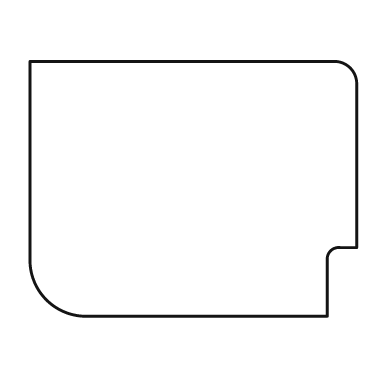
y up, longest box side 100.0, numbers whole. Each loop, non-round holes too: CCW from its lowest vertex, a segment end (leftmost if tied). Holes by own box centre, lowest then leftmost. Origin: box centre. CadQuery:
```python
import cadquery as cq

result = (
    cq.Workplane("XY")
    .moveTo(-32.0, -39.0)
    .lineTo(41.0, -39.0)
    .lineTo(41.0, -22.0)
    .threePointArc((42.0, -19.0), (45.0, -18.0))
    .lineTo(50.0, -18.0)
    .lineTo(50.0, 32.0)
    .threePointArc((48.0, 37.0), (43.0, 39.0))
    .lineTo(-50.0, 39.0)
    .lineTo(-50.0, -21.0)
    .threePointArc((-45.0, -34.0), (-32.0, -39.0))
    .close()
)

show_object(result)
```